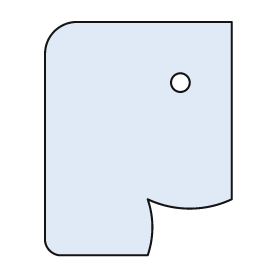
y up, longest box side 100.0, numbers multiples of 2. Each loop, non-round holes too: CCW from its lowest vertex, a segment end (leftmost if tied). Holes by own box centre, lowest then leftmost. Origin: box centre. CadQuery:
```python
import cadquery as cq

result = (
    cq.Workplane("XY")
    .moveTo(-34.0, -50.0)
    .lineTo(4.0, -50.0)
    .threePointArc((6.0, -38.0), (4.0, -26.0))
    .threePointArc((22.0, -30.0), (40.0, -26.0))
    .lineTo(40.0, 50.0)
    .lineTo(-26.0, 50.0)
    .threePointArc((-36.0, 46.0), (-40.0, 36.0))
    .lineTo(-40.0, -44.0)
    .threePointArc((-38.0, -48.0), (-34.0, -50.0))
    .close()
    .moveTo(18.0, 24.0)
    .circle(4.0)
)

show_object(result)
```